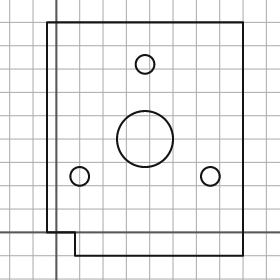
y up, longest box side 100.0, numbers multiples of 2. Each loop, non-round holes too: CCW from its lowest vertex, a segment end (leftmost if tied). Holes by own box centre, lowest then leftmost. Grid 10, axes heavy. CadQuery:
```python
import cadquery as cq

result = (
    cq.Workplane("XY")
    .moveTo(8.0, -10.0)
    .lineTo(80.0, -10.0)
    .lineTo(80.0, 90.0)
    .lineTo(-4.0, 90.0)
    .lineTo(-4.0, 0.0)
    .lineTo(8.0, 0.0)
    .close()
    .moveTo(10.0, 24.0)
    .circle(4.0)
    .moveTo(66.0, 24.0)
    .circle(4.0)
    .moveTo(38.0, 40.0)
    .circle(12.0)
    .moveTo(38.0, 72.0)
    .circle(4.0)
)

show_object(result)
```